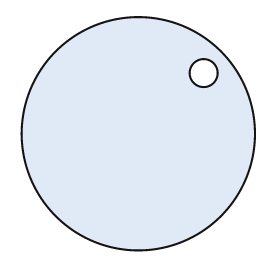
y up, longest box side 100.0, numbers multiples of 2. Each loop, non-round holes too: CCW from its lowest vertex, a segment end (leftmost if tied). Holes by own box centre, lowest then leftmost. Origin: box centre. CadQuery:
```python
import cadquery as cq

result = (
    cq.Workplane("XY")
    .moveTo(0.0, 0.0)
    .circle(50.0)
    .moveTo(28.0, 26.0)
    .circle(6.0)
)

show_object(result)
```